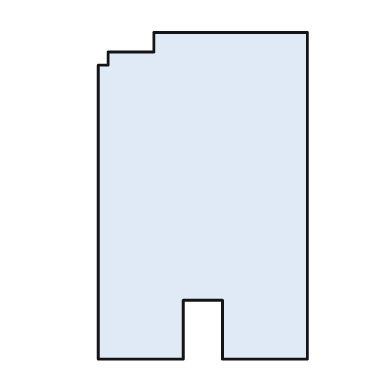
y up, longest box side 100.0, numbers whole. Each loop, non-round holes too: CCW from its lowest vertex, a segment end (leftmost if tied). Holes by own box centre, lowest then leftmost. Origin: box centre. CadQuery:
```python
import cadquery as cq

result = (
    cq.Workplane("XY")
    .moveTo(-32.0, -50.0)
    .lineTo(-6.0, -50.0)
    .lineTo(-6.0, -32.0)
    .lineTo(6.0, -32.0)
    .lineTo(6.0, -50.0)
    .lineTo(32.0, -50.0)
    .lineTo(32.0, 50.0)
    .lineTo(-15.0, 50.0)
    .lineTo(-15.0, 44.0)
    .lineTo(-29.0, 44.0)
    .lineTo(-29.0, 40.0)
    .lineTo(-32.0, 40.0)
    .close()
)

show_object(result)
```